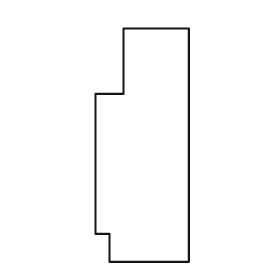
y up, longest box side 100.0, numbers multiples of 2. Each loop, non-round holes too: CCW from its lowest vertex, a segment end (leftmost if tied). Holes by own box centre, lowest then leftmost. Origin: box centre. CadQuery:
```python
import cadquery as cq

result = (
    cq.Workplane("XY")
    .moveTo(-14.0, -50.0)
    .lineTo(20.0, -50.0)
    .lineTo(20.0, 50.0)
    .lineTo(-8.0, 50.0)
    .lineTo(-8.0, 22.0)
    .lineTo(-20.0, 22.0)
    .lineTo(-20.0, -38.0)
    .lineTo(-14.0, -38.0)
    .close()
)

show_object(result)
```